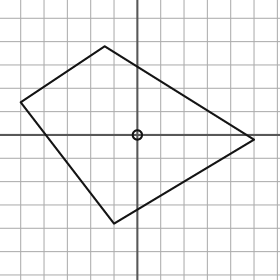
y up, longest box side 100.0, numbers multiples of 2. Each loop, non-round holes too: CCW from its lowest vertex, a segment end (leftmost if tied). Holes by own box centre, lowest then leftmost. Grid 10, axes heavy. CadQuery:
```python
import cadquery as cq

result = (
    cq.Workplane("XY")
    .moveTo(-10.0, -38.0)
    .lineTo(50.0, -2.0)
    .lineTo(-14.0, 38.0)
    .lineTo(-50.0, 14.0)
    .close()
    .moveTo(0.0, 0.0)
    .circle(2.0)
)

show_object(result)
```